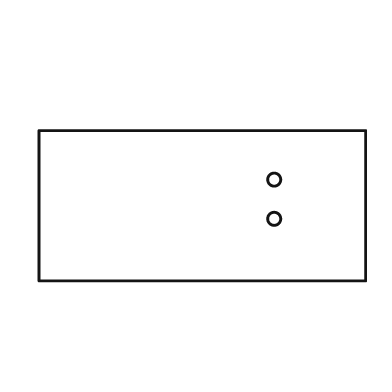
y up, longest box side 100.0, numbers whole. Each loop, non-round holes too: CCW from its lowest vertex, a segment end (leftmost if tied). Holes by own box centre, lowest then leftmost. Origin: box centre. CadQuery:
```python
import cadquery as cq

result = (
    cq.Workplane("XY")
    .moveTo(-50.0, -23.0)
    .lineTo(50.0, -23.0)
    .lineTo(50.0, 23.0)
    .lineTo(-50.0, 23.0)
    .close()
    .moveTo(22.0, -4.0)
    .circle(2.0)
    .moveTo(22.0, 8.0)
    .circle(2.0)
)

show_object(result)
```